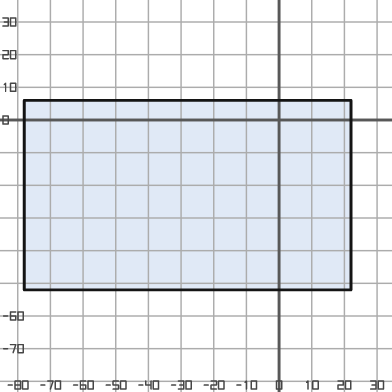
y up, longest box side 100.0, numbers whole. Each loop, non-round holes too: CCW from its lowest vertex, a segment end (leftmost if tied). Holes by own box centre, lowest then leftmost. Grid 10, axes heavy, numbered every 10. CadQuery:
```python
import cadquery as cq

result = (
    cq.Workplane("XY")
    .moveTo(-78.0, -52.0)
    .lineTo(22.0, -52.0)
    .lineTo(22.0, 6.0)
    .lineTo(-78.0, 6.0)
    .close()
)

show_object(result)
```